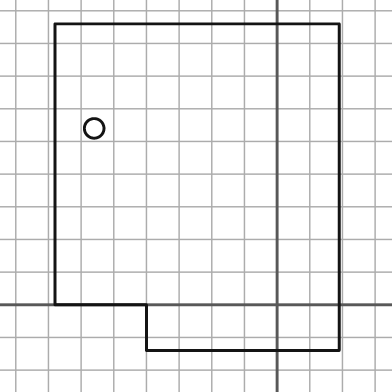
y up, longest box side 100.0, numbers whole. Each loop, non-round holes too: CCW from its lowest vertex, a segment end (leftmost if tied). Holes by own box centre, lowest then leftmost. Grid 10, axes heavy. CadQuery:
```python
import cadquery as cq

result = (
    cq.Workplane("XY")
    .moveTo(-40.0, -14.0)
    .lineTo(19.0, -14.0)
    .lineTo(19.0, 86.0)
    .lineTo(-68.0, 86.0)
    .lineTo(-68.0, 0.0)
    .lineTo(-40.0, 0.0)
    .close()
    .moveTo(-56.0, 54.0)
    .circle(3.0)
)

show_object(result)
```